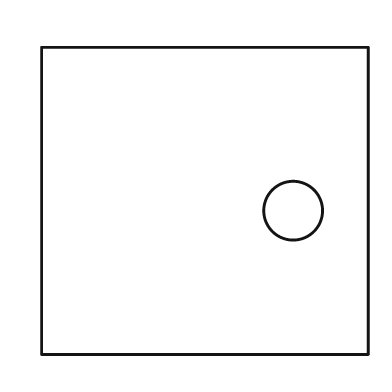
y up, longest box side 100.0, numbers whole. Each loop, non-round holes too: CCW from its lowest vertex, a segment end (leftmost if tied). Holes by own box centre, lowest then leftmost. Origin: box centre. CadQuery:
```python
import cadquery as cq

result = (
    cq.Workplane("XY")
    .moveTo(-50.0, -47.0)
    .lineTo(50.0, -47.0)
    .lineTo(50.0, 47.0)
    .lineTo(-50.0, 47.0)
    .close()
    .moveTo(27.0, -3.0)
    .circle(9.0)
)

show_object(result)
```